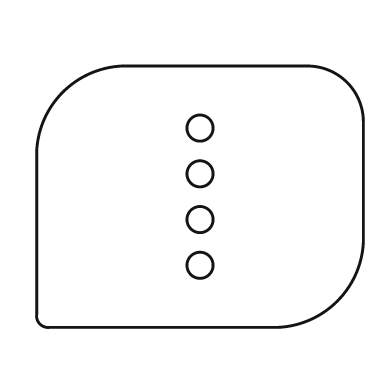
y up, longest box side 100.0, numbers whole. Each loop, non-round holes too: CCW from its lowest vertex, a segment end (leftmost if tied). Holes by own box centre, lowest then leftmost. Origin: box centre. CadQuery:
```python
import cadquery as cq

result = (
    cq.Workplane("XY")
    .moveTo(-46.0, -40.0)
    .lineTo(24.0, -40.0)
    .threePointArc((42.0, -32.0), (50.0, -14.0))
    .lineTo(50.0, 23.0)
    .threePointArc((45.0, 35.0), (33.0, 40.0))
    .lineTo(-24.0, 40.0)
    .threePointArc((-42.0, 32.0), (-50.0, 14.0))
    .lineTo(-50.0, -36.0)
    .threePointArc((-49.0, -39.0), (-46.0, -40.0))
    .close()
    .moveTo(0.0, -21.0)
    .circle(4.0)
    .moveTo(0.0, -7.0)
    .circle(4.0)
    .moveTo(0.0, 7.0)
    .circle(4.0)
    .moveTo(0.0, 21.0)
    .circle(4.0)
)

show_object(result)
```